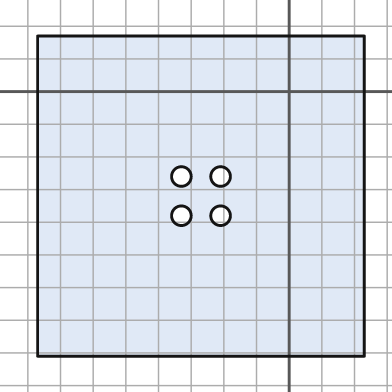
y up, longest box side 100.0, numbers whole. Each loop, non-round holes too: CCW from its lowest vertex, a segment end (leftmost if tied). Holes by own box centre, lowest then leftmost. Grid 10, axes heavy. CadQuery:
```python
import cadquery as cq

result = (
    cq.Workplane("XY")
    .moveTo(-77.0, -81.0)
    .lineTo(23.0, -81.0)
    .lineTo(23.0, 17.0)
    .lineTo(-77.0, 17.0)
    .close()
    .moveTo(-33.0, -38.0)
    .circle(3.0)
    .moveTo(-21.0, -38.0)
    .circle(3.0)
    .moveTo(-33.0, -26.0)
    .circle(3.0)
    .moveTo(-21.0, -26.0)
    .circle(3.0)
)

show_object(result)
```